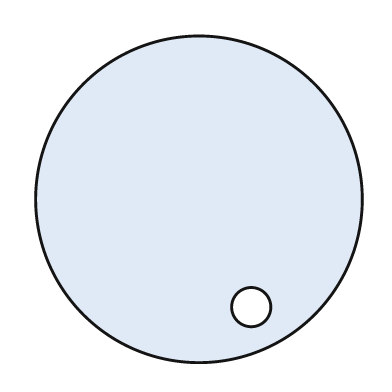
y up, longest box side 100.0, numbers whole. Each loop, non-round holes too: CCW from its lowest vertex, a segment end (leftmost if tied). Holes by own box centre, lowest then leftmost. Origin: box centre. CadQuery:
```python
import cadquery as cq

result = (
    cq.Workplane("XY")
    .moveTo(0.0, 0.0)
    .circle(50.0)
    .moveTo(16.0, -33.0)
    .circle(6.0)
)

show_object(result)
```